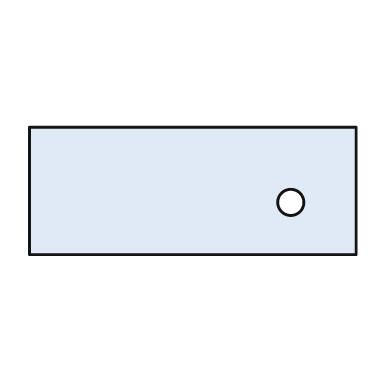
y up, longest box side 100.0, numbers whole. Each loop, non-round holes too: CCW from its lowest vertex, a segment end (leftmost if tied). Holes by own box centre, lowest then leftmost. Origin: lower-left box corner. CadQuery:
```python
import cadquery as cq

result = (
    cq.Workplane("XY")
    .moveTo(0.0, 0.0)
    .lineTo(100.0, 0.0)
    .lineTo(100.0, 39.0)
    .lineTo(0.0, 39.0)
    .close()
    .moveTo(80.0, 16.0)
    .circle(4.0)
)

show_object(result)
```